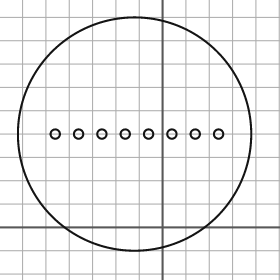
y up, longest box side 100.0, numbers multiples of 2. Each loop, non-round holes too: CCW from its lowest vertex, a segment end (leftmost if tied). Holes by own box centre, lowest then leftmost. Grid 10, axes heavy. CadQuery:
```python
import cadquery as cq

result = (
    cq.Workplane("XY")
    .moveTo(-12.0, 40.0)
    .circle(50.0)
    .moveTo(-46.0, 40.0)
    .circle(2.0)
    .moveTo(-36.0, 40.0)
    .circle(2.0)
    .moveTo(-26.0, 40.0)
    .circle(2.0)
    .moveTo(-16.0, 40.0)
    .circle(2.0)
    .moveTo(-6.0, 40.0)
    .circle(2.0)
    .moveTo(4.0, 40.0)
    .circle(2.0)
    .moveTo(14.0, 40.0)
    .circle(2.0)
    .moveTo(24.0, 40.0)
    .circle(2.0)
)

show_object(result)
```